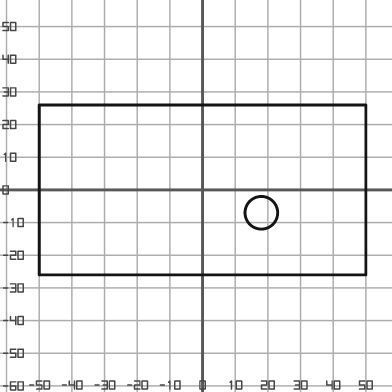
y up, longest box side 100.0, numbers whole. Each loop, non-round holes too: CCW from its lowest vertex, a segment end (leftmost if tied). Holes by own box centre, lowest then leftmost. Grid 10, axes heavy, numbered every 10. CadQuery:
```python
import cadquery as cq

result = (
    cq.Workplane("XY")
    .moveTo(-50.0, -26.0)
    .lineTo(50.0, -26.0)
    .lineTo(50.0, 26.0)
    .lineTo(-50.0, 26.0)
    .close()
    .moveTo(18.0, -7.0)
    .circle(5.0)
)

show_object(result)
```